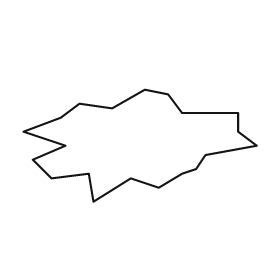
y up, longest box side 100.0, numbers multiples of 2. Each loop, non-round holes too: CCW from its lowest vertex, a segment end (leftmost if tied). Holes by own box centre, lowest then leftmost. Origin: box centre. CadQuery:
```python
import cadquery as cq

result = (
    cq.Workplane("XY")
    .moveTo(-20.0, -24.0)
    .lineTo(-4.0, -14.0)
    .lineTo(8.0, -18.0)
    .lineTo(18.0, -12.0)
    .lineTo(24.0, -10.0)
    .lineTo(28.0, -4.0)
    .lineTo(50.0, 0.0)
    .lineTo(42.0, 6.0)
    .lineTo(42.0, 14.0)
    .lineTo(18.0, 14.0)
    .lineTo(12.0, 22.0)
    .lineTo(2.0, 24.0)
    .lineTo(-12.0, 16.0)
    .lineTo(-26.0, 18.0)
    .lineTo(-34.0, 12.0)
    .lineTo(-50.0, 6.0)
    .lineTo(-32.0, 0.0)
    .lineTo(-46.0, -6.0)
    .lineTo(-38.0, -14.0)
    .lineTo(-22.0, -12.0)
    .close()
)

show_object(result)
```